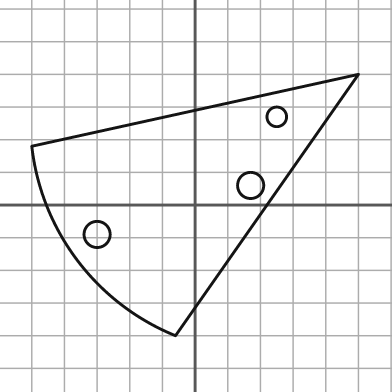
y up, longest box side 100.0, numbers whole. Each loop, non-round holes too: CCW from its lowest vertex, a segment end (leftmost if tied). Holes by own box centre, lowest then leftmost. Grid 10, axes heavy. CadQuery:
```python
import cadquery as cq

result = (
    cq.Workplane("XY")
    .moveTo(-6.0, -40.0)
    .lineTo(50.0, 40.0)
    .lineTo(-50.0, 18.0)
    .threePointArc((-36.0, -17.0), (-6.0, -40.0))
    .close()
    .moveTo(-30.0, -9.0)
    .circle(4.0)
    .moveTo(17.0, 6.0)
    .circle(4.0)
    .moveTo(25.0, 27.0)
    .circle(3.0)
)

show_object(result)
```